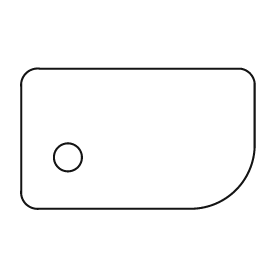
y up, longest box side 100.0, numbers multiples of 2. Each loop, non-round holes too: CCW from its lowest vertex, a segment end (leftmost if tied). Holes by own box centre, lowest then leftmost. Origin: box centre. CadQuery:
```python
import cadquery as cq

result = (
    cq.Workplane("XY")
    .moveTo(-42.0, -30.0)
    .lineTo(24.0, -30.0)
    .threePointArc((42.0, -22.0), (50.0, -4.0))
    .lineTo(50.0, 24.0)
    .threePointArc((48.0, 28.0), (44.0, 30.0))
    .lineTo(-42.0, 30.0)
    .threePointArc((-48.0, 28.0), (-50.0, 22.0))
    .lineTo(-50.0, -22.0)
    .threePointArc((-48.0, -28.0), (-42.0, -30.0))
    .close()
    .moveTo(-30.0, -8.0)
    .circle(6.0)
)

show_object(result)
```